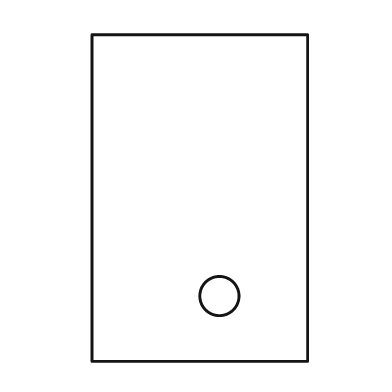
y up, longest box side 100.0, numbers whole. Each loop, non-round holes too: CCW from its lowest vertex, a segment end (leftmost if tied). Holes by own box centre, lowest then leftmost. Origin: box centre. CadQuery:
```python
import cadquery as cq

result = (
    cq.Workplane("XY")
    .moveTo(-33.0, -50.0)
    .lineTo(33.0, -50.0)
    .lineTo(33.0, 50.0)
    .lineTo(-33.0, 50.0)
    .close()
    .moveTo(6.0, -30.0)
    .circle(6.0)
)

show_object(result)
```